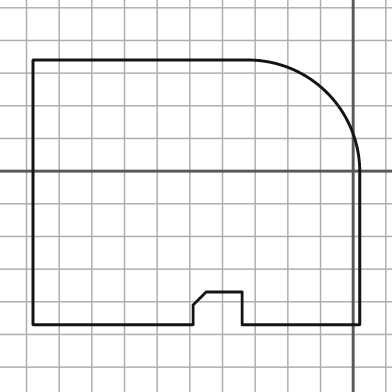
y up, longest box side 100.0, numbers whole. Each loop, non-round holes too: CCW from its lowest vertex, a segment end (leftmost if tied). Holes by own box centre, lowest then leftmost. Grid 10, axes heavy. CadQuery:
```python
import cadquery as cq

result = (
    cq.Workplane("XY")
    .moveTo(-98.0, -47.0)
    .lineTo(-49.0, -47.0)
    .lineTo(-49.0, -41.0)
    .lineTo(-45.0, -37.0)
    .lineTo(-34.0, -37.0)
    .lineTo(-34.0, -47.0)
    .lineTo(2.0, -47.0)
    .lineTo(2.0, 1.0)
    .threePointArc((-8.0, 24.0), (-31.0, 34.0))
    .lineTo(-98.0, 34.0)
    .close()
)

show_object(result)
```